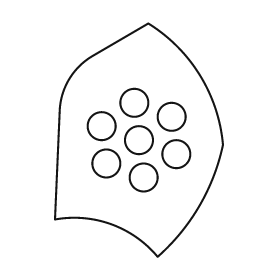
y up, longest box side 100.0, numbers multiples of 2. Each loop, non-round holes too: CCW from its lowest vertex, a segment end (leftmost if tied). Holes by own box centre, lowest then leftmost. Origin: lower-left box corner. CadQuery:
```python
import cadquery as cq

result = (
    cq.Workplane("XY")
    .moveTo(44.0, 0.0)
    .threePointArc((62.0, 22.0), (72.0, 48.0))
    .threePointArc((62.0, 78.0), (40.0, 100.0))
    .lineTo(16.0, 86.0)
    .threePointArc((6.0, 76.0), (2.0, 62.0))
    .lineTo(0.0, 16.0)
    .threePointArc((24.0, 14.0), (44.0, 0.0))
    .close()
    .moveTo(38.0, 34.0)
    .circle(6.0)
    .moveTo(22.0, 40.0)
    .circle(6.0)
    .moveTo(52.0, 44.0)
    .circle(6.0)
    .moveTo(36.0, 50.0)
    .circle(6.0)
    .moveTo(20.0, 56.0)
    .circle(6.0)
    .moveTo(50.0, 60.0)
    .circle(6.0)
    .moveTo(34.0, 66.0)
    .circle(6.0)
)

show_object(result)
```